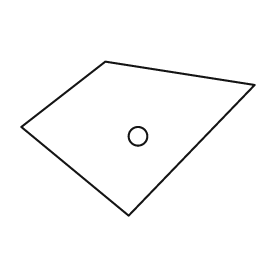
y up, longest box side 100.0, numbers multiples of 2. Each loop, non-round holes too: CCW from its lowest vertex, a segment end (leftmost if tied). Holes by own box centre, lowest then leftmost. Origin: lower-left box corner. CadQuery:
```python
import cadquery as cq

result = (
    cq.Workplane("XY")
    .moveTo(46.0, 0.0)
    .lineTo(100.0, 56.0)
    .lineTo(36.0, 66.0)
    .lineTo(0.0, 38.0)
    .close()
    .moveTo(50.0, 34.0)
    .circle(4.0)
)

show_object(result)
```